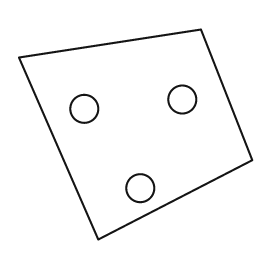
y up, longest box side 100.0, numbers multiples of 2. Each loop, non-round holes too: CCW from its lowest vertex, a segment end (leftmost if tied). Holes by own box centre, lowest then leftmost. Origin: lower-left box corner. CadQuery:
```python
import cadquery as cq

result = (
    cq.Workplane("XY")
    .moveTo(34.0, 0.0)
    .lineTo(100.0, 34.0)
    .lineTo(78.0, 90.0)
    .lineTo(0.0, 78.0)
    .close()
    .moveTo(52.0, 22.0)
    .circle(6.0)
    .moveTo(28.0, 56.0)
    .circle(6.0)
    .moveTo(70.0, 60.0)
    .circle(6.0)
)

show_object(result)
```